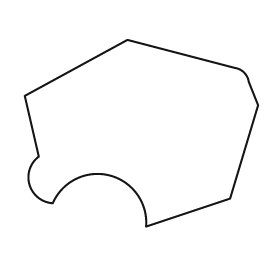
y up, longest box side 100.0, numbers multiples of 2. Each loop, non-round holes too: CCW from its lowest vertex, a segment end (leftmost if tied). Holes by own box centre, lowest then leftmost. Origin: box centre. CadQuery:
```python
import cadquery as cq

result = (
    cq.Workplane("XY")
    .moveTo(2.0, -40.0)
    .lineTo(38.0, -28.0)
    .lineTo(50.0, 12.0)
    .lineTo(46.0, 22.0)
    .threePointArc((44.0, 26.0), (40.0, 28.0))
    .lineTo(-6.0, 40.0)
    .lineTo(-50.0, 16.0)
    .lineTo(-44.0, -10.0)
    .threePointArc((-48.0, -22.0), (-38.0, -30.0))
    .threePointArc((-14.0, -18.0), (2.0, -40.0))
    .close()
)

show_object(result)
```